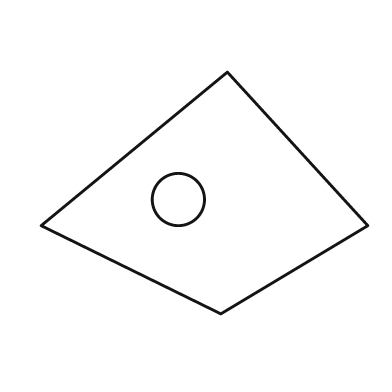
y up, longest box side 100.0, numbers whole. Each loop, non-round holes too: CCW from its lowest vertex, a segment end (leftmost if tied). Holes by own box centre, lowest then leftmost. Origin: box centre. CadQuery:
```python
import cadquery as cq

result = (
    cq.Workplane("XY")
    .moveTo(5.0, -37.0)
    .lineTo(50.0, -10.0)
    .lineTo(7.0, 37.0)
    .lineTo(-50.0, -10.0)
    .close()
    .moveTo(-8.0, -2.0)
    .circle(8.0)
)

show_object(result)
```